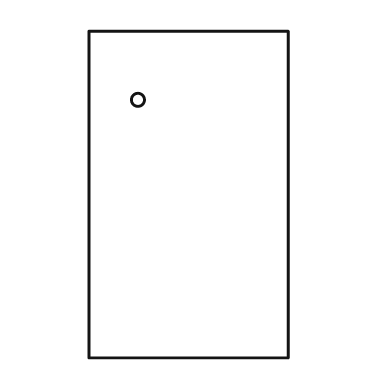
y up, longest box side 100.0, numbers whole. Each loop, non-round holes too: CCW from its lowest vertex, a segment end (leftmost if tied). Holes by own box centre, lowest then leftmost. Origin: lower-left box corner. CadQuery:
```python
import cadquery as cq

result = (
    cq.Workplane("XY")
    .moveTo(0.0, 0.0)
    .lineTo(61.0, 0.0)
    .lineTo(61.0, 100.0)
    .lineTo(0.0, 100.0)
    .close()
    .moveTo(15.0, 79.0)
    .circle(2.0)
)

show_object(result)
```